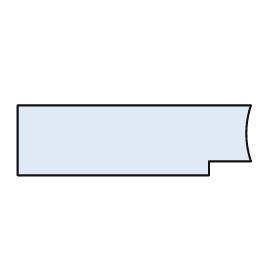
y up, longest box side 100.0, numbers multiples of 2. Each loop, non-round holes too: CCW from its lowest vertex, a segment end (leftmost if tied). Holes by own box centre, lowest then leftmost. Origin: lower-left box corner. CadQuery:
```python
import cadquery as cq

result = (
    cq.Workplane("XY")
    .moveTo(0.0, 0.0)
    .lineTo(82.0, 0.0)
    .lineTo(82.0, 6.0)
    .lineTo(100.0, 6.0)
    .threePointArc((98.0, 18.0), (100.0, 30.0))
    .lineTo(0.0, 30.0)
    .close()
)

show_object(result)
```